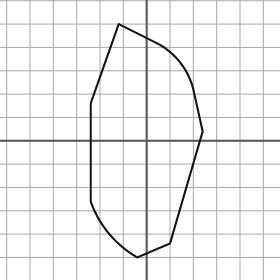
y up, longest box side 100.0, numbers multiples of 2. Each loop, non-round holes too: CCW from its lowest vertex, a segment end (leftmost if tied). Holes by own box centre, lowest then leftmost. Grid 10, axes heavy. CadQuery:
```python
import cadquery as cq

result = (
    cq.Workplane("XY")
    .moveTo(-4.0, -50.0)
    .lineTo(10.0, -44.0)
    .lineTo(24.0, 4.0)
    .lineTo(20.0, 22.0)
    .threePointArc((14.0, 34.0), (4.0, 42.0))
    .lineTo(-12.0, 50.0)
    .lineTo(-24.0, 16.0)
    .lineTo(-24.0, -26.0)
    .threePointArc((-16.0, -40.0), (-4.0, -50.0))
    .close()
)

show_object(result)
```